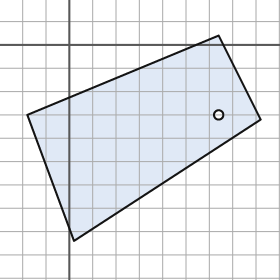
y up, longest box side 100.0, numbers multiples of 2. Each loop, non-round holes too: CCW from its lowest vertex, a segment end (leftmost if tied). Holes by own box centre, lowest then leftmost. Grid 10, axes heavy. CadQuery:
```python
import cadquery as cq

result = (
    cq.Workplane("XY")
    .moveTo(2.0, -84.0)
    .lineTo(82.0, -32.0)
    .lineTo(64.0, 4.0)
    .lineTo(-18.0, -30.0)
    .close()
    .moveTo(64.0, -30.0)
    .circle(2.0)
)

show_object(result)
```